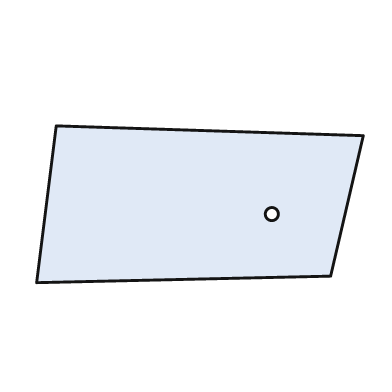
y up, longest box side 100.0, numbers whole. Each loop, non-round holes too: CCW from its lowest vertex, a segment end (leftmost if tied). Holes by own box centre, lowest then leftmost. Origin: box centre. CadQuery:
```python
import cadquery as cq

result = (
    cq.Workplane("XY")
    .moveTo(-50.0, -24.0)
    .lineTo(40.0, -22.0)
    .lineTo(50.0, 21.0)
    .lineTo(-44.0, 24.0)
    .close()
    .moveTo(22.0, -3.0)
    .circle(2.0)
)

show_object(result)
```